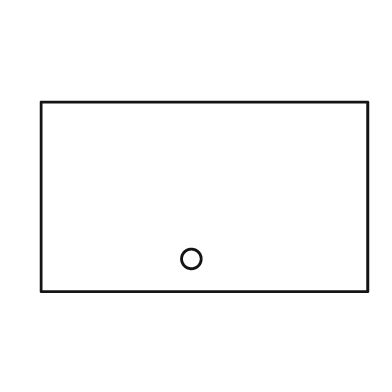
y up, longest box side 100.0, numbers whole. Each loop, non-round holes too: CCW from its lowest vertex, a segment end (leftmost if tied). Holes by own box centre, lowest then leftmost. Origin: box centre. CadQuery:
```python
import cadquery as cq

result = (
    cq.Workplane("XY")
    .moveTo(-50.0, -29.0)
    .lineTo(50.0, -29.0)
    .lineTo(50.0, 29.0)
    .lineTo(-50.0, 29.0)
    .close()
    .moveTo(-4.0, -19.0)
    .circle(3.0)
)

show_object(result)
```